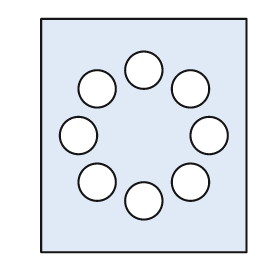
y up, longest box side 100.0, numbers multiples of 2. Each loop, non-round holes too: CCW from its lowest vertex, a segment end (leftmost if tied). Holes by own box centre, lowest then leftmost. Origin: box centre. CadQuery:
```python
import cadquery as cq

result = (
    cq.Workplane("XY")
    .moveTo(-44.0, -50.0)
    .lineTo(44.0, -50.0)
    .lineTo(44.0, 50.0)
    .lineTo(-44.0, 50.0)
    .close()
    .moveTo(0.0, -28.0)
    .circle(8.0)
    .moveTo(-20.0, -20.0)
    .circle(8.0)
    .moveTo(20.0, -20.0)
    .circle(8.0)
    .moveTo(-28.0, 0.0)
    .circle(8.0)
    .moveTo(28.0, 0.0)
    .circle(8.0)
    .moveTo(-20.0, 20.0)
    .circle(8.0)
    .moveTo(20.0, 20.0)
    .circle(8.0)
    .moveTo(0.0, 28.0)
    .circle(8.0)
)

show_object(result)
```